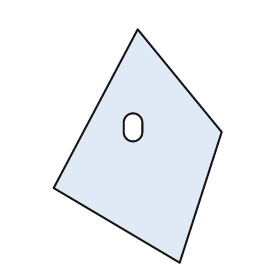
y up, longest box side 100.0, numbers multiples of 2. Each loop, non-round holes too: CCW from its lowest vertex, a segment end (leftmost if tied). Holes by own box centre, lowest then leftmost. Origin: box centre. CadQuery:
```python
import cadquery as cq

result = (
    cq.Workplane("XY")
    .moveTo(18.0, -50.0)
    .lineTo(36.0, 6.0)
    .lineTo(0.0, 50.0)
    .lineTo(-36.0, -18.0)
    .close()
    .moveTo(-6.0, 6.0)
    .threePointArc((-2.0, 2.0), (2.0, 6.0))
    .lineTo(2.0, 10.0)
    .threePointArc((-2.0, 14.0), (-6.0, 10.0))
    .close()
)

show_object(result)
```